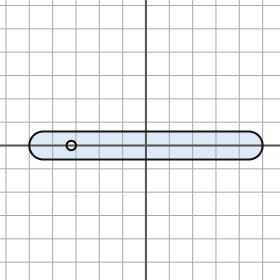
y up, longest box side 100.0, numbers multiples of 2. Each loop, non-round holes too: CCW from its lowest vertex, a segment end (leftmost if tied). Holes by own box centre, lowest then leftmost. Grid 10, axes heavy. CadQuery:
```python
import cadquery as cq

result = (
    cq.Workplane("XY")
    .moveTo(-44.0, -6.0)
    .lineTo(44.0, -6.0)
    .threePointArc((50.0, 0.0), (44.0, 6.0))
    .lineTo(-44.0, 6.0)
    .threePointArc((-50.0, 0.0), (-44.0, -6.0))
    .close()
    .moveTo(-32.0, 0.0)
    .circle(2.0)
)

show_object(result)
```